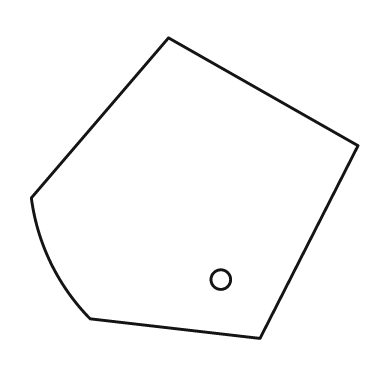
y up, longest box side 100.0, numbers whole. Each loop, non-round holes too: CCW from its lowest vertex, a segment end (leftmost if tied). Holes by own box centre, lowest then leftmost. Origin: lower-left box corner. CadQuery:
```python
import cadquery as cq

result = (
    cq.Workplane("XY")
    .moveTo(70.0, 0.0)
    .lineTo(100.0, 59.0)
    .lineTo(42.0, 92.0)
    .lineTo(0.0, 43.0)
    .threePointArc((6.0, 23.0), (18.0, 6.0))
    .close()
    .moveTo(58.0, 18.0)
    .circle(3.0)
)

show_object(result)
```